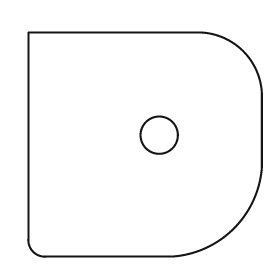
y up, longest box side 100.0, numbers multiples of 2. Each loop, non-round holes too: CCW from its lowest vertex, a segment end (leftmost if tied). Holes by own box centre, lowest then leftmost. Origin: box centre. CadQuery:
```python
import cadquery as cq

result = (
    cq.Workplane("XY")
    .moveTo(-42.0, -48.0)
    .lineTo(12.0, -48.0)
    .threePointArc((38.0, -36.0), (50.0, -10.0))
    .lineTo(50.0, 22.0)
    .threePointArc((42.0, 40.0), (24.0, 48.0))
    .lineTo(-50.0, 48.0)
    .lineTo(-50.0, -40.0)
    .threePointArc((-48.0, -46.0), (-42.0, -48.0))
    .close()
    .moveTo(6.0, 4.0)
    .circle(8.0)
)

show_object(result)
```